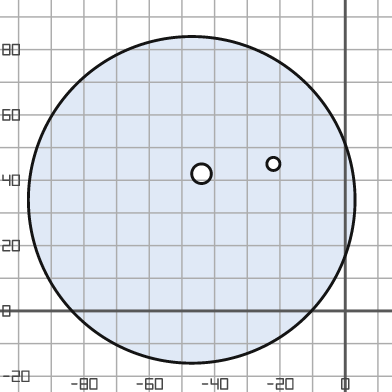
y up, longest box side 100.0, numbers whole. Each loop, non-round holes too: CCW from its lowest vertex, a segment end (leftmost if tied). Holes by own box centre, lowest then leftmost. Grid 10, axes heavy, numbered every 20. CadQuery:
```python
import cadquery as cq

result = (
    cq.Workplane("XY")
    .moveTo(-47.0, 34.0)
    .circle(50.0)
    .moveTo(-44.0, 42.0)
    .circle(3.0)
    .moveTo(-22.0, 45.0)
    .circle(2.0)
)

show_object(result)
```